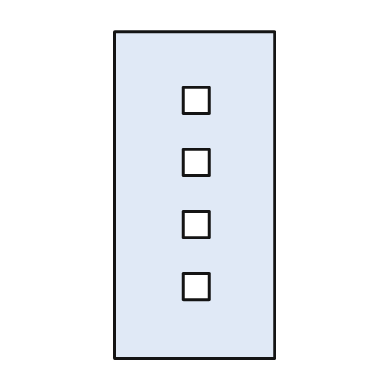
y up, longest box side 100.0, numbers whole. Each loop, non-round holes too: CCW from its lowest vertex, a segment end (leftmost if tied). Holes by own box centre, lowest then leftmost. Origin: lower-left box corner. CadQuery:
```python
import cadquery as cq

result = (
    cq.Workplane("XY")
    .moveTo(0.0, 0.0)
    .lineTo(49.0, 0.0)
    .lineTo(49.0, 100.0)
    .lineTo(0.0, 100.0)
    .close()
    .moveTo(21.0, 18.0)
    .lineTo(29.0, 18.0)
    .lineTo(29.0, 26.0)
    .lineTo(21.0, 26.0)
    .close()
    .moveTo(21.0, 37.0)
    .lineTo(29.0, 37.0)
    .lineTo(29.0, 45.0)
    .lineTo(21.0, 45.0)
    .close()
    .moveTo(21.0, 56.0)
    .lineTo(29.0, 56.0)
    .lineTo(29.0, 64.0)
    .lineTo(21.0, 64.0)
    .close()
    .moveTo(21.0, 75.0)
    .lineTo(29.0, 75.0)
    .lineTo(29.0, 83.0)
    .lineTo(21.0, 83.0)
    .close()
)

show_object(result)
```